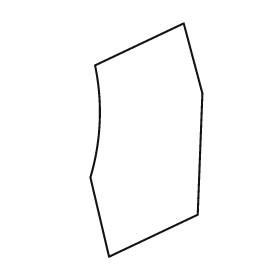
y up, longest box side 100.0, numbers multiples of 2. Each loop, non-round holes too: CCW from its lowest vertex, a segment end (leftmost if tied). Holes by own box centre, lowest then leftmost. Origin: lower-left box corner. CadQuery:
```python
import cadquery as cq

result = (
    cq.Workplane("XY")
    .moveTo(8.0, 0.0)
    .lineTo(46.0, 18.0)
    .lineTo(48.0, 70.0)
    .lineTo(40.0, 100.0)
    .lineTo(2.0, 82.0)
    .threePointArc((4.0, 58.0), (0.0, 34.0))
    .close()
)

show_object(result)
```